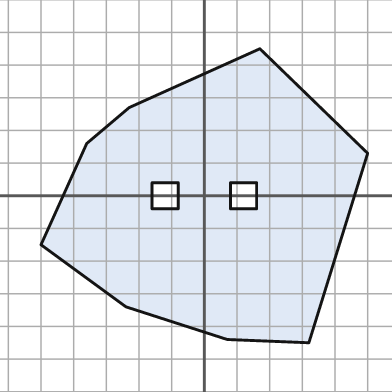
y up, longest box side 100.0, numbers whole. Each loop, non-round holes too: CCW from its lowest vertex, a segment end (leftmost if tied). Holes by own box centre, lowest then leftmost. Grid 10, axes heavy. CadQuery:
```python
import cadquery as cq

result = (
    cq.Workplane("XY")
    .moveTo(32.0, -45.0)
    .lineTo(50.0, 13.0)
    .lineTo(17.0, 45.0)
    .lineTo(-23.0, 27.0)
    .lineTo(-36.0, 16.0)
    .lineTo(-50.0, -15.0)
    .lineTo(-24.0, -34.0)
    .lineTo(7.0, -44.0)
    .close()
    .moveTo(-16.0, -4.0)
    .lineTo(-8.0, -4.0)
    .lineTo(-8.0, 4.0)
    .lineTo(-16.0, 4.0)
    .close()
    .moveTo(8.0, -4.0)
    .lineTo(16.0, -4.0)
    .lineTo(16.0, 4.0)
    .lineTo(8.0, 4.0)
    .close()
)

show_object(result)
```